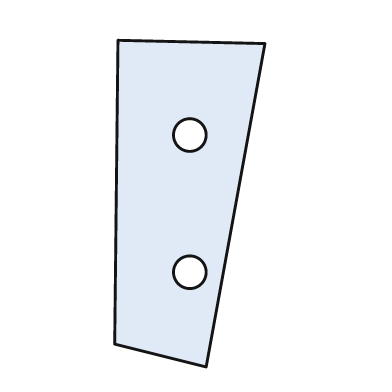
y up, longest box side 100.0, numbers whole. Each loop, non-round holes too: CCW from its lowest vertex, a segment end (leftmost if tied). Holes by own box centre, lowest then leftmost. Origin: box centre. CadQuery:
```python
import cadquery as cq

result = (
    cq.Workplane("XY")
    .moveTo(5.0, -50.0)
    .lineTo(23.0, 49.0)
    .lineTo(-22.0, 50.0)
    .lineTo(-23.0, -43.0)
    .close()
    .moveTo(0.0, -21.0)
    .circle(5.0)
    .moveTo(0.0, 21.0)
    .circle(5.0)
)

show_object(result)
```